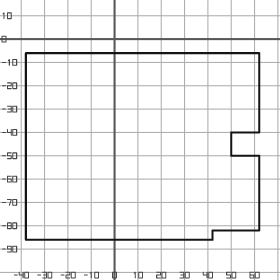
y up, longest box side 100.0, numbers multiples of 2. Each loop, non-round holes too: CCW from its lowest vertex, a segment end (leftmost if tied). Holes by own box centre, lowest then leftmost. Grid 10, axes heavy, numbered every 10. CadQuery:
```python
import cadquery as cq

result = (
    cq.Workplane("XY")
    .moveTo(-38.0, -86.0)
    .lineTo(42.0, -86.0)
    .lineTo(42.0, -82.0)
    .lineTo(62.0, -82.0)
    .lineTo(62.0, -50.0)
    .lineTo(50.0, -50.0)
    .lineTo(50.0, -40.0)
    .lineTo(62.0, -40.0)
    .lineTo(62.0, -6.0)
    .lineTo(-38.0, -6.0)
    .close()
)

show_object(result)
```